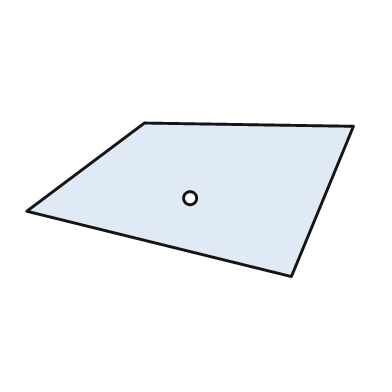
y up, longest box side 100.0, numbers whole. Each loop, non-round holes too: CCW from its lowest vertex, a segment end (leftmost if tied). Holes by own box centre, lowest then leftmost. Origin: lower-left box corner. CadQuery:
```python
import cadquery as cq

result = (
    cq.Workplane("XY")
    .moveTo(81.0, 0.0)
    .lineTo(100.0, 46.0)
    .lineTo(36.0, 47.0)
    .lineTo(0.0, 20.0)
    .close()
    .moveTo(50.0, 24.0)
    .circle(2.0)
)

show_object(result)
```